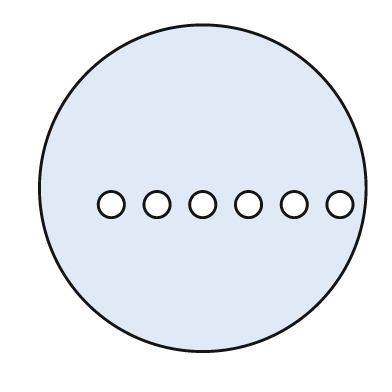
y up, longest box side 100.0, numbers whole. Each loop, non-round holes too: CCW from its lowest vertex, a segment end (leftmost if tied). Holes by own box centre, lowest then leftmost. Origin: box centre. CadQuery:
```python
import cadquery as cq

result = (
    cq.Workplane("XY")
    .moveTo(0.0, 0.0)
    .circle(50.0)
    .moveTo(-28.0, -5.0)
    .circle(4.0)
    .moveTo(-14.0, -5.0)
    .circle(4.0)
    .moveTo(0.0, -5.0)
    .circle(4.0)
    .moveTo(14.0, -5.0)
    .circle(4.0)
    .moveTo(28.0, -5.0)
    .circle(4.0)
    .moveTo(42.0, -5.0)
    .circle(4.0)
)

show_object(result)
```